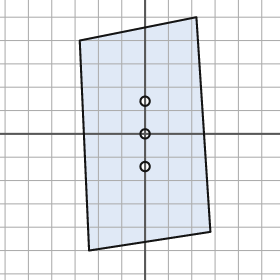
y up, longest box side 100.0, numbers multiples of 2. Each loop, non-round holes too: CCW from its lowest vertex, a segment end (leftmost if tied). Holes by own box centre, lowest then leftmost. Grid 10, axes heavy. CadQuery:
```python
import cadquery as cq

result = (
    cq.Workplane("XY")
    .moveTo(-24.0, -50.0)
    .lineTo(28.0, -42.0)
    .lineTo(22.0, 50.0)
    .lineTo(-28.0, 40.0)
    .close()
    .moveTo(0.0, -14.0)
    .circle(2.0)
    .moveTo(0.0, 0.0)
    .circle(2.0)
    .moveTo(0.0, 14.0)
    .circle(2.0)
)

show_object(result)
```